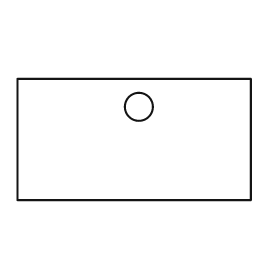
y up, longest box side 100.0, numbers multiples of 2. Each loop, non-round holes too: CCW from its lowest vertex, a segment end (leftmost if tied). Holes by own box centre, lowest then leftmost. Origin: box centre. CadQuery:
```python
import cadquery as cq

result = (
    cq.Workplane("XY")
    .moveTo(-50.0, -26.0)
    .lineTo(50.0, -26.0)
    .lineTo(50.0, 26.0)
    .lineTo(-50.0, 26.0)
    .close()
    .moveTo(2.0, 14.0)
    .circle(6.0)
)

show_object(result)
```